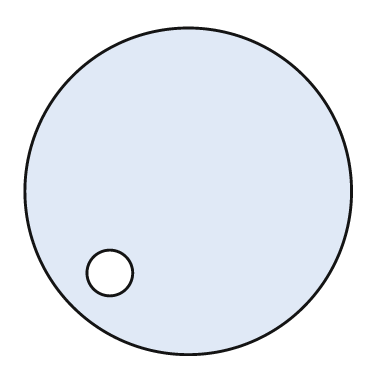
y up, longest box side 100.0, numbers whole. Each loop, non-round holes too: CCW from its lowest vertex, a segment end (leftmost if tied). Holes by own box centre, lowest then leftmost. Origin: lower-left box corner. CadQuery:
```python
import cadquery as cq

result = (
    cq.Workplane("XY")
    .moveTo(50.0, 50.0)
    .circle(50.0)
    .moveTo(26.0, 25.0)
    .circle(7.0)
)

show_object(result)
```